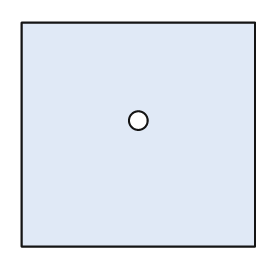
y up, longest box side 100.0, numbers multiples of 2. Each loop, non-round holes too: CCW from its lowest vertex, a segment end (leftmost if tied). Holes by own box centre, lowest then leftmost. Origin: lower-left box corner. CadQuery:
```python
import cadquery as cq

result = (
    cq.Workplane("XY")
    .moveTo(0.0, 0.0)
    .lineTo(100.0, 0.0)
    .lineTo(100.0, 96.0)
    .lineTo(0.0, 96.0)
    .close()
    .moveTo(50.0, 54.0)
    .circle(4.0)
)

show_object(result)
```